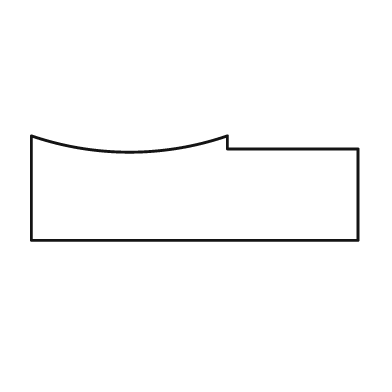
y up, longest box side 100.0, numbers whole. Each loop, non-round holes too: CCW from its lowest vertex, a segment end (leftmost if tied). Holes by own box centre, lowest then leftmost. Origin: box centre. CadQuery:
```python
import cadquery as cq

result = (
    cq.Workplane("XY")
    .moveTo(-50.0, -16.0)
    .lineTo(50.0, -16.0)
    .lineTo(50.0, 12.0)
    .lineTo(10.0, 12.0)
    .lineTo(10.0, 16.0)
    .threePointArc((-20.0, 11.0), (-50.0, 16.0))
    .close()
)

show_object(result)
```